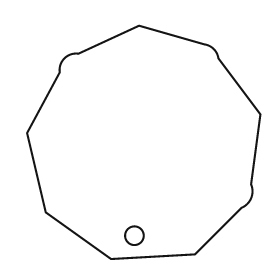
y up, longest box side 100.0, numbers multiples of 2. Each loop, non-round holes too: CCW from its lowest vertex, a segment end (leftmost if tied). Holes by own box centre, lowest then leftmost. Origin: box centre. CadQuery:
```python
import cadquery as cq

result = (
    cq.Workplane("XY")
    .moveTo(-14.0, -50.0)
    .lineTo(22.0, -48.0)
    .lineTo(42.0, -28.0)
    .threePointArc((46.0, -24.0), (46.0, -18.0))
    .lineTo(50.0, 12.0)
    .lineTo(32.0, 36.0)
    .threePointArc((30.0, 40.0), (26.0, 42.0))
    .lineTo(-2.0, 50.0)
    .lineTo(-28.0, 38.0)
    .threePointArc((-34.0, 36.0), (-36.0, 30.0))
    .lineTo(-50.0, 4.0)
    .lineTo(-42.0, -30.0)
    .close()
    .moveTo(-4.0, -40.0)
    .circle(4.0)
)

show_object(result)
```